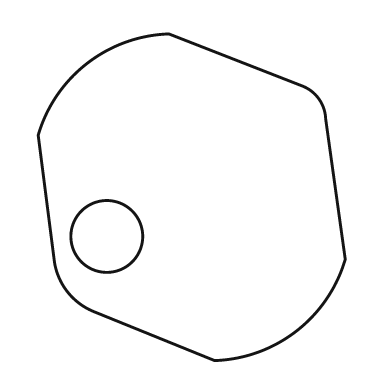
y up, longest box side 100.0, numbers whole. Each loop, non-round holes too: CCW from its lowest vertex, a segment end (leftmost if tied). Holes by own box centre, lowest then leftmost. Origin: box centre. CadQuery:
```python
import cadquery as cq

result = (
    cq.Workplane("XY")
    .moveTo(7.0, -50.0)
    .threePointArc((32.0, -41.0), (47.0, -19.0))
    .lineTo(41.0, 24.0)
    .threePointArc((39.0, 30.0), (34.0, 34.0))
    .lineTo(-7.0, 50.0)
    .threePointArc((-32.0, 41.0), (-47.0, 19.0))
    .lineTo(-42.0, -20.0)
    .threePointArc((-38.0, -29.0), (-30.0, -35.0))
    .close()
    .moveTo(-26.0, -12.0)
    .circle(11.0)
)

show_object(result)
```